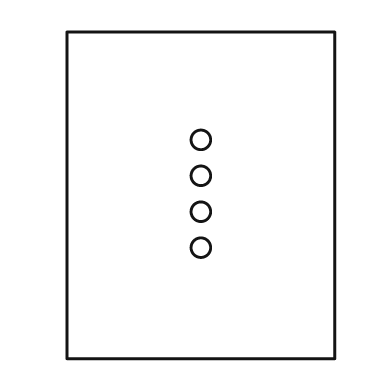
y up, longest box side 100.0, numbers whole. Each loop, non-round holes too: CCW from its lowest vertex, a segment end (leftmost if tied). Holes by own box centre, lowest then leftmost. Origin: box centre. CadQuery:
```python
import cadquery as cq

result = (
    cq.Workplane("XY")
    .moveTo(-41.0, -50.0)
    .lineTo(41.0, -50.0)
    .lineTo(41.0, 50.0)
    .lineTo(-41.0, 50.0)
    .close()
    .moveTo(0.0, -16.0)
    .circle(3.0)
    .moveTo(0.0, -5.0)
    .circle(3.0)
    .moveTo(0.0, 6.0)
    .circle(3.0)
    .moveTo(0.0, 17.0)
    .circle(3.0)
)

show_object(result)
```